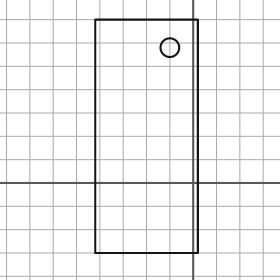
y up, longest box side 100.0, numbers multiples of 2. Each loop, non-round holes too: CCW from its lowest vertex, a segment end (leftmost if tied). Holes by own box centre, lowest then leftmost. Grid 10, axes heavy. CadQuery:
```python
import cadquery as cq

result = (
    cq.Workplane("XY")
    .moveTo(-42.0, -30.0)
    .lineTo(2.0, -30.0)
    .lineTo(2.0, 70.0)
    .lineTo(-42.0, 70.0)
    .close()
    .moveTo(-10.0, 58.0)
    .circle(4.0)
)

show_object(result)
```